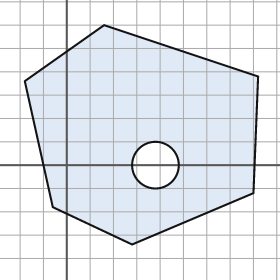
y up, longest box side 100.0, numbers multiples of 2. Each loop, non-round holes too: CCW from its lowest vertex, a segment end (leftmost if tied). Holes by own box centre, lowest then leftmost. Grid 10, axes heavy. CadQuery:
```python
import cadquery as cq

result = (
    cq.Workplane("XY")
    .moveTo(28.0, -34.0)
    .lineTo(80.0, -12.0)
    .lineTo(82.0, 38.0)
    .lineTo(16.0, 60.0)
    .lineTo(-18.0, 36.0)
    .lineTo(-6.0, -18.0)
    .close()
    .moveTo(38.0, 0.0)
    .circle(10.0)
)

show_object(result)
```